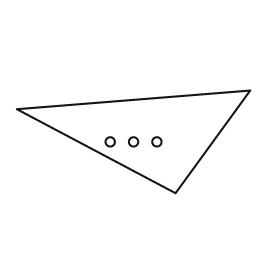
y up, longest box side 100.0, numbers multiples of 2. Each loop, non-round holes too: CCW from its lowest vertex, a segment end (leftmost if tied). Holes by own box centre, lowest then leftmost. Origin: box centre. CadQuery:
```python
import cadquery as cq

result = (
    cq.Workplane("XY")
    .moveTo(18.0, -22.0)
    .lineTo(50.0, 22.0)
    .lineTo(-50.0, 14.0)
    .close()
    .moveTo(-10.0, 0.0)
    .circle(2.0)
    .moveTo(0.0, 0.0)
    .circle(2.0)
    .moveTo(10.0, 0.0)
    .circle(2.0)
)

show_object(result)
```